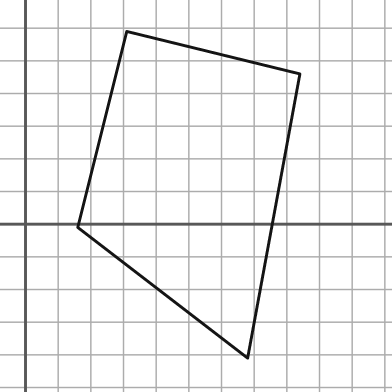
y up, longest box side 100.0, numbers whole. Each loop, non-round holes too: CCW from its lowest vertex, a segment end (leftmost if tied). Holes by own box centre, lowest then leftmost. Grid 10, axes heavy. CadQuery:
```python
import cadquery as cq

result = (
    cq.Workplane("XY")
    .moveTo(68.0, -41.0)
    .lineTo(84.0, 46.0)
    .lineTo(31.0, 59.0)
    .lineTo(16.0, -1.0)
    .close()
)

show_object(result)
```